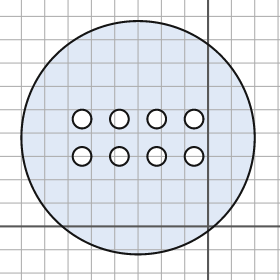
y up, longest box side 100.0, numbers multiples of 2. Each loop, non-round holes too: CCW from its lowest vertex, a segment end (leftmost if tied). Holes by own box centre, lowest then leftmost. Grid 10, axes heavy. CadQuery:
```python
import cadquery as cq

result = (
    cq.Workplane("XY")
    .moveTo(-30.0, 38.0)
    .circle(50.0)
    .moveTo(-54.0, 30.0)
    .circle(4.0)
    .moveTo(-38.0, 30.0)
    .circle(4.0)
    .moveTo(-22.0, 30.0)
    .circle(4.0)
    .moveTo(-6.0, 30.0)
    .circle(4.0)
    .moveTo(-54.0, 46.0)
    .circle(4.0)
    .moveTo(-38.0, 46.0)
    .circle(4.0)
    .moveTo(-22.0, 46.0)
    .circle(4.0)
    .moveTo(-6.0, 46.0)
    .circle(4.0)
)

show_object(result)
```